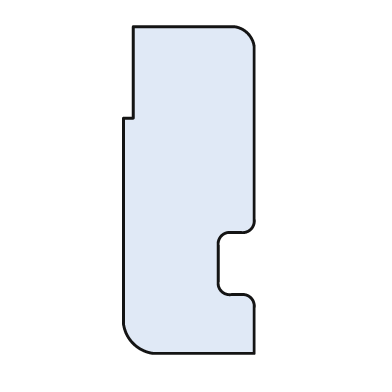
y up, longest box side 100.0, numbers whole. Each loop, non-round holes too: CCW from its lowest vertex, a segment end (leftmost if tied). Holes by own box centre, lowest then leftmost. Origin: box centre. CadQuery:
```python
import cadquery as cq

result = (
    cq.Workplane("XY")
    .moveTo(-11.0, -50.0)
    .lineTo(20.0, -50.0)
    .lineTo(20.0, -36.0)
    .threePointArc((19.0, -33.0), (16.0, -32.0))
    .lineTo(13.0, -32.0)
    .threePointArc((10.0, -31.0), (9.0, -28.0))
    .lineTo(9.0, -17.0)
    .threePointArc((10.0, -14.0), (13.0, -13.0))
    .lineTo(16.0, -13.0)
    .threePointArc((19.0, -12.0), (20.0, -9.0))
    .lineTo(20.0, 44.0)
    .threePointArc((18.0, 48.0), (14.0, 50.0))
    .lineTo(-17.0, 50.0)
    .lineTo(-17.0, 22.0)
    .lineTo(-20.0, 22.0)
    .lineTo(-20.0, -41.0)
    .threePointArc((-17.0, -47.0), (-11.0, -50.0))
    .close()
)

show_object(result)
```